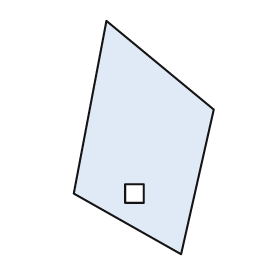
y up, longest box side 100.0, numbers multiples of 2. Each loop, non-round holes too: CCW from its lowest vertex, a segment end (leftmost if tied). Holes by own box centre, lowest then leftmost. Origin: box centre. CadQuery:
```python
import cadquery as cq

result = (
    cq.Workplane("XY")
    .moveTo(16.0, -50.0)
    .lineTo(30.0, 12.0)
    .lineTo(-16.0, 50.0)
    .lineTo(-30.0, -24.0)
    .close()
    .moveTo(-8.0, -28.0)
    .lineTo(0.0, -28.0)
    .lineTo(0.0, -20.0)
    .lineTo(-8.0, -20.0)
    .close()
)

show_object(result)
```